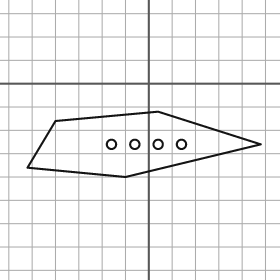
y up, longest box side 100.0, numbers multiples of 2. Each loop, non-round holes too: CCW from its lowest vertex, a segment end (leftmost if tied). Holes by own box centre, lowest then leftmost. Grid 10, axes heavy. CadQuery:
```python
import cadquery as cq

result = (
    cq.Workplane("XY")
    .moveTo(-10.0, -40.0)
    .lineTo(48.0, -26.0)
    .lineTo(4.0, -12.0)
    .lineTo(-40.0, -16.0)
    .lineTo(-52.0, -36.0)
    .close()
    .moveTo(-16.0, -26.0)
    .circle(2.0)
    .moveTo(-6.0, -26.0)
    .circle(2.0)
    .moveTo(4.0, -26.0)
    .circle(2.0)
    .moveTo(14.0, -26.0)
    .circle(2.0)
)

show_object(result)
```